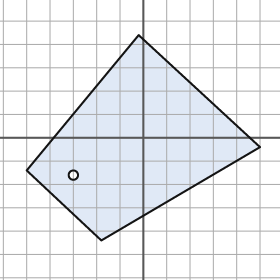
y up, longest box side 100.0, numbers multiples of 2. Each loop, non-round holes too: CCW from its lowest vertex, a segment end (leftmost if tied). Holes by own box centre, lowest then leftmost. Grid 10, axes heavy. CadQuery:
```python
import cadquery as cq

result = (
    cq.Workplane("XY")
    .moveTo(-18.0, -44.0)
    .lineTo(50.0, -4.0)
    .lineTo(-2.0, 44.0)
    .lineTo(-50.0, -14.0)
    .close()
    .moveTo(-30.0, -16.0)
    .circle(2.0)
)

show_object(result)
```